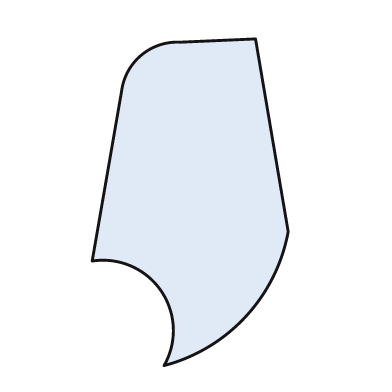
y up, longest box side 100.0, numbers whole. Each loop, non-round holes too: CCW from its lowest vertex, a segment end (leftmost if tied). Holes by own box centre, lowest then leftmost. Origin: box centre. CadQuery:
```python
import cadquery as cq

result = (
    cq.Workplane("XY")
    .moveTo(-8.0, -50.0)
    .threePointArc((17.0, -35.0), (30.0, -9.0))
    .lineTo(20.0, 50.0)
    .lineTo(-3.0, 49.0)
    .threePointArc((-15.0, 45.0), (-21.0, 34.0))
    .lineTo(-30.0, -18.0)
    .threePointArc((-9.0, -27.0), (-8.0, -50.0))
    .close()
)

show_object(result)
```